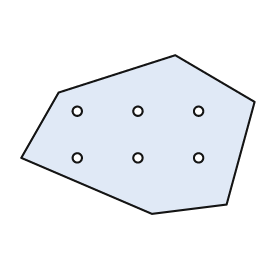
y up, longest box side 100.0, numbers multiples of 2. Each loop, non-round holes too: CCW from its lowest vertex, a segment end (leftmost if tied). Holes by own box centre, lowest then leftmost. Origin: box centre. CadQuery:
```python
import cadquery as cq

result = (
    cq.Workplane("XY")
    .moveTo(6.0, -34.0)
    .lineTo(38.0, -30.0)
    .lineTo(50.0, 14.0)
    .lineTo(16.0, 34.0)
    .lineTo(-34.0, 18.0)
    .lineTo(-50.0, -10.0)
    .close()
    .moveTo(-26.0, -10.0)
    .circle(2.0)
    .moveTo(0.0, -10.0)
    .circle(2.0)
    .moveTo(26.0, -10.0)
    .circle(2.0)
    .moveTo(-26.0, 10.0)
    .circle(2.0)
    .moveTo(0.0, 10.0)
    .circle(2.0)
    .moveTo(26.0, 10.0)
    .circle(2.0)
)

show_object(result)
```